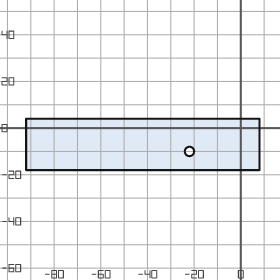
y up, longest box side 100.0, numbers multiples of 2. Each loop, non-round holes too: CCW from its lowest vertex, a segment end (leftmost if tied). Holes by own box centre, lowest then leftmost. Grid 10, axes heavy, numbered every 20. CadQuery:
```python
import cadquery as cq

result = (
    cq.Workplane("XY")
    .moveTo(-92.0, -18.0)
    .lineTo(8.0, -18.0)
    .lineTo(8.0, 4.0)
    .lineTo(-92.0, 4.0)
    .close()
    .moveTo(-22.0, -10.0)
    .circle(2.0)
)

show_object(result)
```